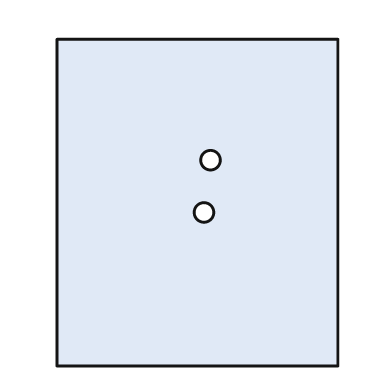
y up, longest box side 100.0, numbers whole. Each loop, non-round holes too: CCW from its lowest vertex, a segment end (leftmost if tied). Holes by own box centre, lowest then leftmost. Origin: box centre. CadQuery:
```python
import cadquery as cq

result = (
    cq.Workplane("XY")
    .moveTo(-43.0, -50.0)
    .lineTo(43.0, -50.0)
    .lineTo(43.0, 50.0)
    .lineTo(-43.0, 50.0)
    .close()
    .moveTo(2.0, -3.0)
    .circle(3.0)
    .moveTo(4.0, 13.0)
    .circle(3.0)
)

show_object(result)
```